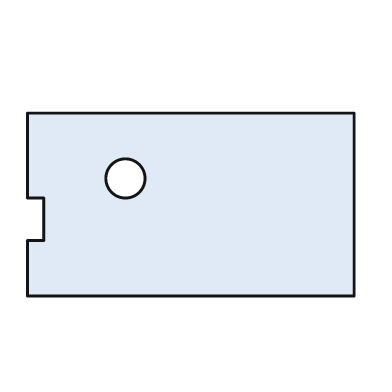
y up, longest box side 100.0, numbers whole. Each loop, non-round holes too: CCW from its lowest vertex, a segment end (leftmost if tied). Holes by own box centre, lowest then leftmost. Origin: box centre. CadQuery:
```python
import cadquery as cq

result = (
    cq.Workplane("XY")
    .moveTo(-50.0, -28.0)
    .lineTo(50.0, -28.0)
    .lineTo(50.0, 28.0)
    .lineTo(-50.0, 28.0)
    .lineTo(-50.0, 2.0)
    .lineTo(-45.0, 2.0)
    .lineTo(-45.0, -11.0)
    .lineTo(-50.0, -11.0)
    .close()
    .moveTo(-20.0, 8.0)
    .circle(6.0)
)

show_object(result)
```